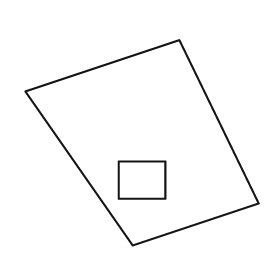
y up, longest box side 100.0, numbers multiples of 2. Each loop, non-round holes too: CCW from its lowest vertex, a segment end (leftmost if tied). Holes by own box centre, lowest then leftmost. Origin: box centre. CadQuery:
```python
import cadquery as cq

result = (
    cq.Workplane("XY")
    .moveTo(-4.0, -44.0)
    .lineTo(50.0, -26.0)
    .lineTo(16.0, 44.0)
    .lineTo(-50.0, 22.0)
    .close()
    .moveTo(-10.0, -24.0)
    .lineTo(10.0, -24.0)
    .lineTo(10.0, -8.0)
    .lineTo(-10.0, -8.0)
    .close()
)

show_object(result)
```